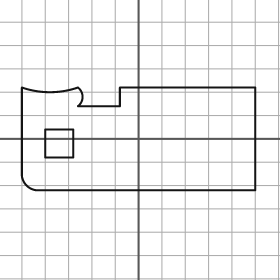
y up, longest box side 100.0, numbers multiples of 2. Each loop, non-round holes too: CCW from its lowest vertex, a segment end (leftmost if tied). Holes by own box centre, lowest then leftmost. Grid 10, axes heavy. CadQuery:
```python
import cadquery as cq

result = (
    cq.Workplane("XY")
    .moveTo(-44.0, -22.0)
    .lineTo(50.0, -22.0)
    .lineTo(50.0, 22.0)
    .lineTo(-8.0, 22.0)
    .lineTo(-8.0, 14.0)
    .lineTo(-26.0, 14.0)
    .threePointArc((-24.0, 18.0), (-26.0, 22.0))
    .threePointArc((-38.0, 20.0), (-50.0, 22.0))
    .lineTo(-50.0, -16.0)
    .threePointArc((-48.0, -20.0), (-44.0, -22.0))
    .close()
    .moveTo(-40.0, -8.0)
    .lineTo(-28.0, -8.0)
    .lineTo(-28.0, 4.0)
    .lineTo(-40.0, 4.0)
    .close()
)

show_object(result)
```